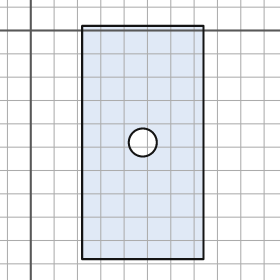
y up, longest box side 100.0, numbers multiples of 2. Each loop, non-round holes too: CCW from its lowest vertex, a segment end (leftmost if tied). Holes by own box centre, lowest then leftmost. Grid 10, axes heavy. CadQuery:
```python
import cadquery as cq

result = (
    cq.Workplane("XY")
    .moveTo(22.0, -98.0)
    .lineTo(74.0, -98.0)
    .lineTo(74.0, 2.0)
    .lineTo(22.0, 2.0)
    .close()
    .moveTo(48.0, -48.0)
    .circle(6.0)
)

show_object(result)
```